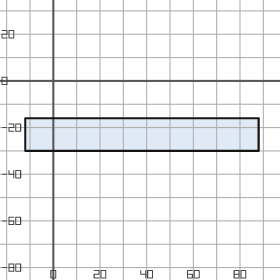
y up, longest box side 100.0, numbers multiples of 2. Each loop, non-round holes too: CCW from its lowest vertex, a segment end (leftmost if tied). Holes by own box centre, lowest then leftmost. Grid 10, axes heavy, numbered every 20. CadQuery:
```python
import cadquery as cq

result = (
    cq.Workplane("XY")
    .moveTo(-12.0, -30.0)
    .lineTo(88.0, -30.0)
    .lineTo(88.0, -16.0)
    .lineTo(-12.0, -16.0)
    .close()
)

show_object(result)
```